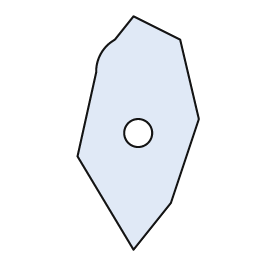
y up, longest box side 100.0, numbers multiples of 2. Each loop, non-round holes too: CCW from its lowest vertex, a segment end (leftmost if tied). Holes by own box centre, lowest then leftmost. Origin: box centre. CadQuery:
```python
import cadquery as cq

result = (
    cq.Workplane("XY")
    .moveTo(-2.0, -50.0)
    .lineTo(14.0, -30.0)
    .lineTo(26.0, 6.0)
    .lineTo(18.0, 40.0)
    .lineTo(-2.0, 50.0)
    .lineTo(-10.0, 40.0)
    .threePointArc((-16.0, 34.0), (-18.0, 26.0))
    .lineTo(-26.0, -10.0)
    .close()
    .moveTo(0.0, 0.0)
    .circle(6.0)
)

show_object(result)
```